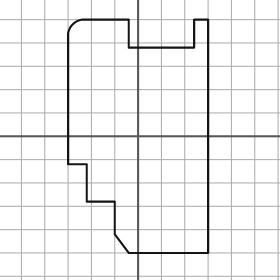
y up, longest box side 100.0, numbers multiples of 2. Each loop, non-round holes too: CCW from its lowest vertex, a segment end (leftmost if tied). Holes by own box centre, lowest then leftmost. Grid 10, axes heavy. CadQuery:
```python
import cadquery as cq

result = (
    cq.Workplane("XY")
    .moveTo(-4.0, -50.0)
    .lineTo(30.0, -50.0)
    .lineTo(30.0, 50.0)
    .lineTo(24.0, 50.0)
    .lineTo(24.0, 38.0)
    .lineTo(-4.0, 38.0)
    .lineTo(-4.0, 50.0)
    .lineTo(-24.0, 50.0)
    .threePointArc((-28.0, 48.0), (-30.0, 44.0))
    .lineTo(-30.0, -12.0)
    .lineTo(-22.0, -12.0)
    .lineTo(-22.0, -28.0)
    .lineTo(-10.0, -28.0)
    .lineTo(-10.0, -42.0)
    .close()
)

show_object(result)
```